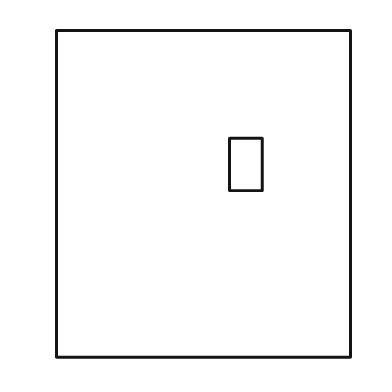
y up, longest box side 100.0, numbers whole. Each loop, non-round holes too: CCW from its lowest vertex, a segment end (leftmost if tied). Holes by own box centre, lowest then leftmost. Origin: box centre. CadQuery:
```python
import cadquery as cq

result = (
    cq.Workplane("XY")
    .moveTo(-45.0, -50.0)
    .lineTo(45.0, -50.0)
    .lineTo(45.0, 50.0)
    .lineTo(-45.0, 50.0)
    .close()
    .moveTo(8.0, 1.0)
    .lineTo(18.0, 1.0)
    .lineTo(18.0, 17.0)
    .lineTo(8.0, 17.0)
    .close()
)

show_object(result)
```